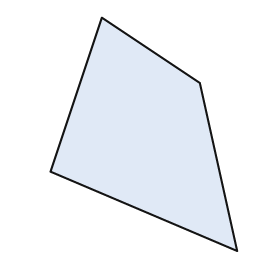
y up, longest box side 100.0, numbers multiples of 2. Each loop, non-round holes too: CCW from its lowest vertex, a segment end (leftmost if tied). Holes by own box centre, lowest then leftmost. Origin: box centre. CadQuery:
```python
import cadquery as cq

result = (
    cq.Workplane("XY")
    .moveTo(40.0, -50.0)
    .lineTo(24.0, 22.0)
    .lineTo(-18.0, 50.0)
    .lineTo(-40.0, -16.0)
    .close()
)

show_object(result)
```